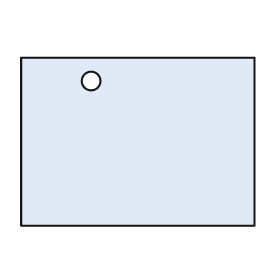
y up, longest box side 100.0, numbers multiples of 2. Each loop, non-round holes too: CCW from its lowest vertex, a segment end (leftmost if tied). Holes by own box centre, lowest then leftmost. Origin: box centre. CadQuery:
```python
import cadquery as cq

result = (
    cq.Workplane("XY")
    .moveTo(-50.0, -36.0)
    .lineTo(50.0, -36.0)
    .lineTo(50.0, 36.0)
    .lineTo(-50.0, 36.0)
    .close()
    .moveTo(-20.0, 26.0)
    .circle(4.0)
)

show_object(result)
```